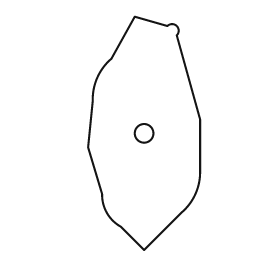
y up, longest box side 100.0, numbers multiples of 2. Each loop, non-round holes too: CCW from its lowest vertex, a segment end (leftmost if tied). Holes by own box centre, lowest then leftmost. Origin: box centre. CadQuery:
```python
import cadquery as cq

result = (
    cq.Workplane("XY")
    .moveTo(0.0, -50.0)
    .lineTo(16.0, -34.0)
    .threePointArc((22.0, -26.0), (24.0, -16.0))
    .lineTo(24.0, 6.0)
    .lineTo(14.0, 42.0)
    .threePointArc((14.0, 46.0), (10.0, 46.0))
    .lineTo(-4.0, 50.0)
    .lineTo(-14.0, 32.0)
    .threePointArc((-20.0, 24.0), (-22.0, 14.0))
    .lineTo(-24.0, -6.0)
    .lineTo(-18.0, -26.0)
    .threePointArc((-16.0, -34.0), (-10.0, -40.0))
    .close()
    .moveTo(0.0, 0.0)
    .circle(4.0)
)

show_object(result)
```